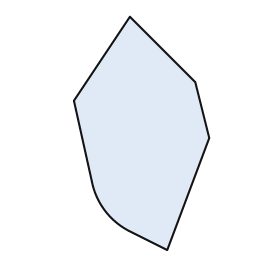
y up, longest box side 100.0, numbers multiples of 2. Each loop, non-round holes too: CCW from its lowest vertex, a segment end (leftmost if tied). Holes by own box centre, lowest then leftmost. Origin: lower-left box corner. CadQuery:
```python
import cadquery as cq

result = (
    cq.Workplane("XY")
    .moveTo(40.0, 0.0)
    .lineTo(58.0, 48.0)
    .lineTo(52.0, 72.0)
    .lineTo(24.0, 100.0)
    .lineTo(0.0, 64.0)
    .lineTo(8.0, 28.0)
    .threePointArc((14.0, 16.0), (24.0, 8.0))
    .close()
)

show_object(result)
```